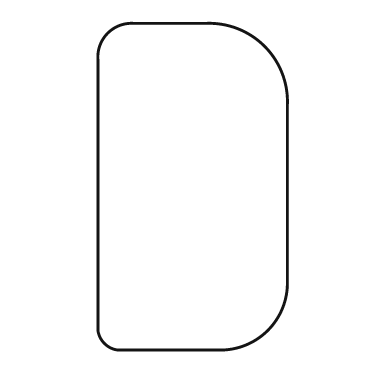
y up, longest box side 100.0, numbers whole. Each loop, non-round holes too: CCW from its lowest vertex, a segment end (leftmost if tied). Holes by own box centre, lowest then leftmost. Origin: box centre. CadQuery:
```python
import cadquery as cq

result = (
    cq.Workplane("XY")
    .moveTo(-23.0, -50.0)
    .lineTo(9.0, -50.0)
    .threePointArc((23.0, -44.0), (29.0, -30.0))
    .lineTo(29.0, 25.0)
    .threePointArc((22.0, 43.0), (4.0, 50.0))
    .lineTo(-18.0, 50.0)
    .threePointArc((-26.0, 47.0), (-29.0, 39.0))
    .lineTo(-29.0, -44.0)
    .threePointArc((-27.0, -48.0), (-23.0, -50.0))
    .close()
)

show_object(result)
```